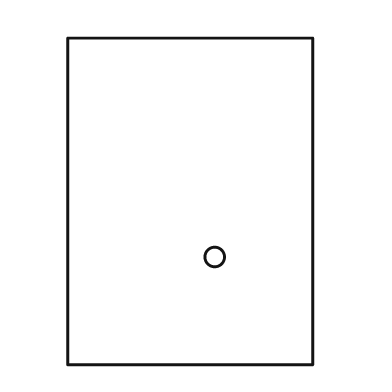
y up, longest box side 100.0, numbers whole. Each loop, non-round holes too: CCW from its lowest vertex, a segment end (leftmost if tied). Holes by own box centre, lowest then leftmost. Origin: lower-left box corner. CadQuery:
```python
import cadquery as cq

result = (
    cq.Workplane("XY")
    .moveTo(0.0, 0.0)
    .lineTo(75.0, 0.0)
    .lineTo(75.0, 100.0)
    .lineTo(0.0, 100.0)
    .close()
    .moveTo(45.0, 33.0)
    .circle(3.0)
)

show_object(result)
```